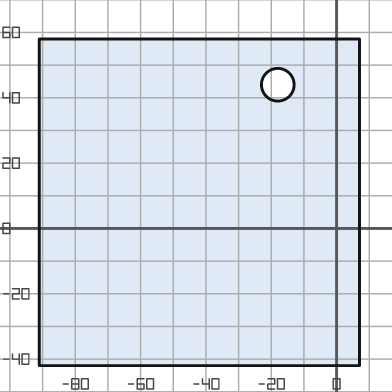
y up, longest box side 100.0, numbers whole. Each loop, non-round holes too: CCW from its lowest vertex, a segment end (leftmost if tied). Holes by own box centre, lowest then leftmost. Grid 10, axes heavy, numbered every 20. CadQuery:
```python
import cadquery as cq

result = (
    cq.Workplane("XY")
    .moveTo(-91.0, -42.0)
    .lineTo(7.0, -42.0)
    .lineTo(7.0, 58.0)
    .lineTo(-91.0, 58.0)
    .close()
    .moveTo(-18.0, 44.0)
    .circle(5.0)
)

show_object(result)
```